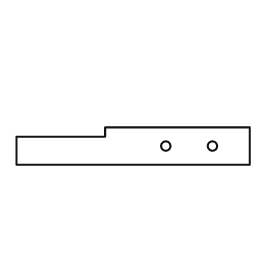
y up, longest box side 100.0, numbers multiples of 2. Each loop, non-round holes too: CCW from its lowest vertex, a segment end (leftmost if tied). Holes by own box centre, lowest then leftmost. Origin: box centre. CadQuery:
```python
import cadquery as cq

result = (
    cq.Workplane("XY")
    .moveTo(-50.0, -8.0)
    .lineTo(50.0, -8.0)
    .lineTo(50.0, 8.0)
    .lineTo(-12.0, 8.0)
    .lineTo(-12.0, 4.0)
    .lineTo(-50.0, 4.0)
    .close()
    .moveTo(14.0, 0.0)
    .circle(2.0)
    .moveTo(34.0, 0.0)
    .circle(2.0)
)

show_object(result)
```